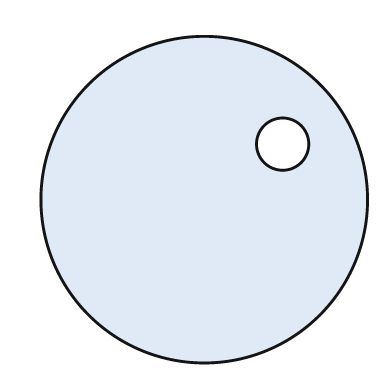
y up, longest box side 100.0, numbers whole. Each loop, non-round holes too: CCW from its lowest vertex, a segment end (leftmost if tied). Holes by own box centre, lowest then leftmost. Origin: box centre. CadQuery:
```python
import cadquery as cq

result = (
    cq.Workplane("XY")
    .moveTo(0.0, 0.0)
    .circle(50.0)
    .moveTo(24.0, 17.0)
    .circle(8.0)
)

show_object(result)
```